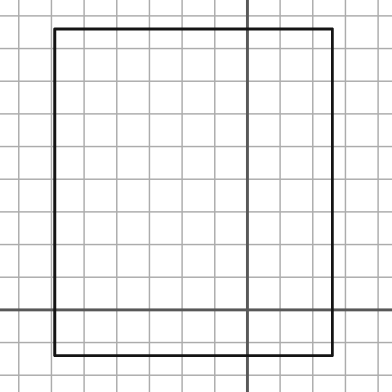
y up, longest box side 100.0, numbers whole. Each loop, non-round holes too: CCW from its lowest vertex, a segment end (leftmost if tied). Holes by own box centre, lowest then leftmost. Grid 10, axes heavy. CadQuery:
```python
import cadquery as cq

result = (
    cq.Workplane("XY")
    .moveTo(-59.0, -14.0)
    .lineTo(26.0, -14.0)
    .lineTo(26.0, 86.0)
    .lineTo(-59.0, 86.0)
    .close()
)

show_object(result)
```